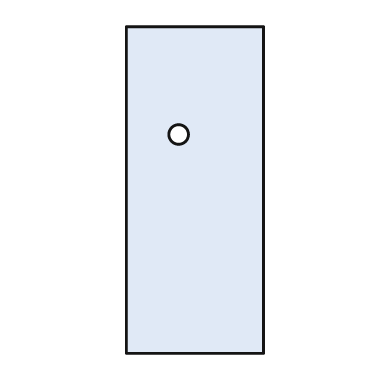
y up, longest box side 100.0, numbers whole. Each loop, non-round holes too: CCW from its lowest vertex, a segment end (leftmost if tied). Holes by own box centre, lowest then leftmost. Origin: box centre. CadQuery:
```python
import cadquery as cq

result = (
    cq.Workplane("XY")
    .moveTo(-21.0, -50.0)
    .lineTo(21.0, -50.0)
    .lineTo(21.0, 50.0)
    .lineTo(-21.0, 50.0)
    .close()
    .moveTo(-5.0, 17.0)
    .circle(3.0)
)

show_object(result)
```